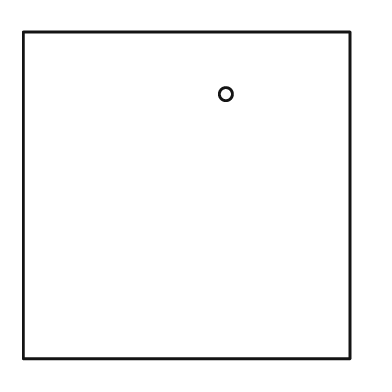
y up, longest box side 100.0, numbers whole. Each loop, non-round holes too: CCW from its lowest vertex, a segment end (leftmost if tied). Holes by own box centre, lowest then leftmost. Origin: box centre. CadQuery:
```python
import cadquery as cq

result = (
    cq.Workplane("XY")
    .moveTo(-50.0, -50.0)
    .lineTo(50.0, -50.0)
    .lineTo(50.0, 50.0)
    .lineTo(-50.0, 50.0)
    .close()
    .moveTo(12.0, 31.0)
    .circle(2.0)
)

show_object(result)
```